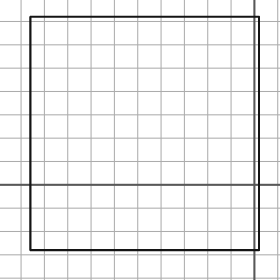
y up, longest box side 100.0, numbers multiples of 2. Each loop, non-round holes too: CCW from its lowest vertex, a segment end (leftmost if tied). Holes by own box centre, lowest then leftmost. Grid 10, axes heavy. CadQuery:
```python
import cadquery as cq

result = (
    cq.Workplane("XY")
    .moveTo(-96.0, -28.0)
    .lineTo(2.0, -28.0)
    .lineTo(2.0, 72.0)
    .lineTo(-96.0, 72.0)
    .close()
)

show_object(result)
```